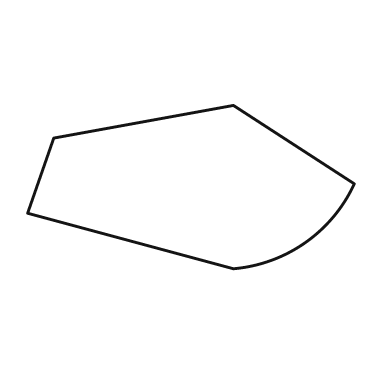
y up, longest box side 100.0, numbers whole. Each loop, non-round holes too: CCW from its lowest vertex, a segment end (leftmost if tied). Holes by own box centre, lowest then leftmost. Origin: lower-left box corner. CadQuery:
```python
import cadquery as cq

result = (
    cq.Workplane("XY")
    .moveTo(63.0, 0.0)
    .threePointArc((85.0, 8.0), (100.0, 26.0))
    .lineTo(63.0, 50.0)
    .lineTo(8.0, 40.0)
    .lineTo(0.0, 17.0)
    .close()
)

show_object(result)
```